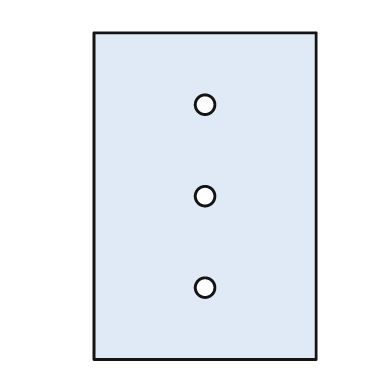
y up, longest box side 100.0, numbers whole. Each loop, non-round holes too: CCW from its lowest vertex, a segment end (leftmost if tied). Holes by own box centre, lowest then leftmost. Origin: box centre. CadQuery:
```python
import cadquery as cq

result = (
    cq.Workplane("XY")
    .moveTo(-34.0, -50.0)
    .lineTo(34.0, -50.0)
    .lineTo(34.0, 50.0)
    .lineTo(-34.0, 50.0)
    .close()
    .moveTo(0.0, -28.0)
    .circle(3.0)
    .moveTo(0.0, 0.0)
    .circle(3.0)
    .moveTo(0.0, 28.0)
    .circle(3.0)
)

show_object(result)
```